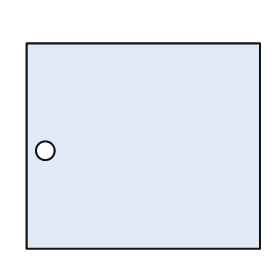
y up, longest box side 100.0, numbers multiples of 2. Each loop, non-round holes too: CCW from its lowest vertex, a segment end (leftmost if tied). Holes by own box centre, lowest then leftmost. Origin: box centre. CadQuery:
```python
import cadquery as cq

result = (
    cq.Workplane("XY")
    .moveTo(-50.0, -44.0)
    .lineTo(50.0, -44.0)
    .lineTo(50.0, 44.0)
    .lineTo(-50.0, 44.0)
    .close()
    .moveTo(-42.0, -2.0)
    .circle(4.0)
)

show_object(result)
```